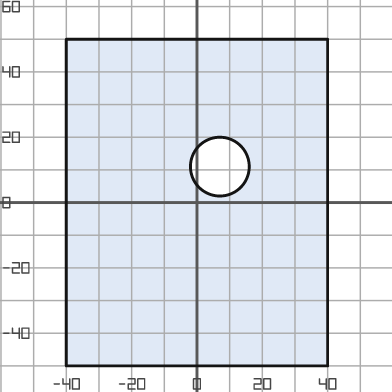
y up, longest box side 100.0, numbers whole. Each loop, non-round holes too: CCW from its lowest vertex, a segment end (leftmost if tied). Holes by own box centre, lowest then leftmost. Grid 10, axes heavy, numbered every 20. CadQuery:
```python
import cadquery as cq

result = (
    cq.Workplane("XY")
    .moveTo(-40.0, -50.0)
    .lineTo(40.0, -50.0)
    .lineTo(40.0, 50.0)
    .lineTo(-40.0, 50.0)
    .close()
    .moveTo(7.0, 11.0)
    .circle(9.0)
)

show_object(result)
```